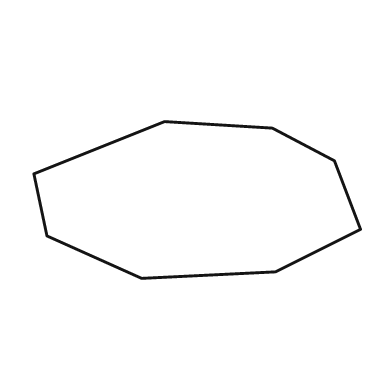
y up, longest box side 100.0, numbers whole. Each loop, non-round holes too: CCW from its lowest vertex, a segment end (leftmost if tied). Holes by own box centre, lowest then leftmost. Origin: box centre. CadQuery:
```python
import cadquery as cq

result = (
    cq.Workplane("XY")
    .moveTo(-17.0, -24.0)
    .lineTo(24.0, -22.0)
    .lineTo(50.0, -9.0)
    .lineTo(42.0, 12.0)
    .lineTo(23.0, 22.0)
    .lineTo(-10.0, 24.0)
    .lineTo(-50.0, 8.0)
    .lineTo(-46.0, -11.0)
    .close()
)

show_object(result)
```